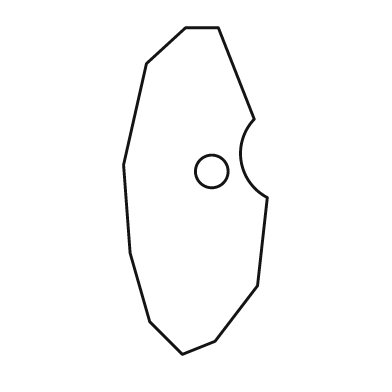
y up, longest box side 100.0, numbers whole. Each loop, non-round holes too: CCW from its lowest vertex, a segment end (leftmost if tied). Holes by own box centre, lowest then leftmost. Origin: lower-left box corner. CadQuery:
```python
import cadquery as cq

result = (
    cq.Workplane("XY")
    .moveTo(18.0, 0.0)
    .lineTo(28.0, 4.0)
    .lineTo(41.0, 21.0)
    .lineTo(44.0, 48.0)
    .threePointArc((36.0, 59.0), (40.0, 72.0))
    .lineTo(29.0, 100.0)
    .lineTo(19.0, 100.0)
    .lineTo(7.0, 89.0)
    .lineTo(0.0, 58.0)
    .lineTo(2.0, 31.0)
    .lineTo(8.0, 10.0)
    .close()
    .moveTo(27.0, 56.0)
    .circle(5.0)
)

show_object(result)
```